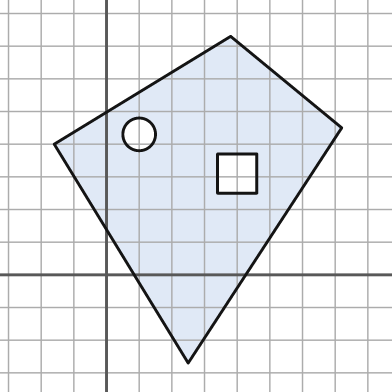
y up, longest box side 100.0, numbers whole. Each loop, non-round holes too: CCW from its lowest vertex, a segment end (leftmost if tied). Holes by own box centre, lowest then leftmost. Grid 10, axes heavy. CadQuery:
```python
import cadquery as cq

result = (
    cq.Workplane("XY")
    .moveTo(25.0, -27.0)
    .lineTo(72.0, 45.0)
    .lineTo(38.0, 73.0)
    .lineTo(-16.0, 40.0)
    .close()
    .moveTo(34.0, 25.0)
    .lineTo(46.0, 25.0)
    .lineTo(46.0, 37.0)
    .lineTo(34.0, 37.0)
    .close()
    .moveTo(10.0, 43.0)
    .circle(5.0)
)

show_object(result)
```